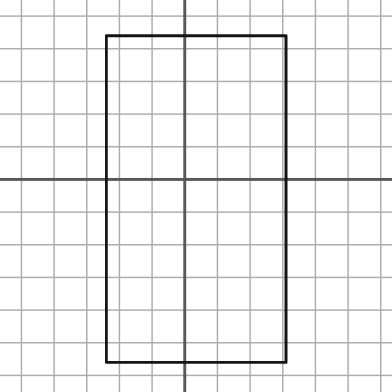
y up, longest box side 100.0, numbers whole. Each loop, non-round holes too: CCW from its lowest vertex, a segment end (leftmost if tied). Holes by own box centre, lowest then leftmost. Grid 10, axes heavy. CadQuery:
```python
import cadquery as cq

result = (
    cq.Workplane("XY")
    .moveTo(-24.0, -56.0)
    .lineTo(31.0, -56.0)
    .lineTo(31.0, 44.0)
    .lineTo(-24.0, 44.0)
    .close()
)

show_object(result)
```